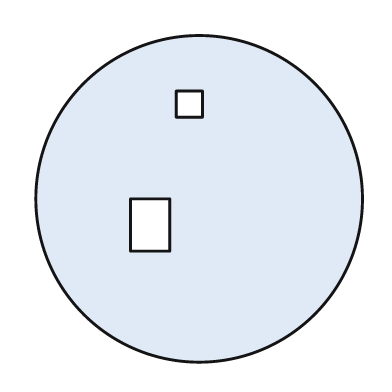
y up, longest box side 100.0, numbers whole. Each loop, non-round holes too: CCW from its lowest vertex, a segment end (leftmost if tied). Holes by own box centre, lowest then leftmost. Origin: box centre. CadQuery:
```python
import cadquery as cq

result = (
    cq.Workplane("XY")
    .moveTo(0.0, 0.0)
    .circle(50.0)
    .moveTo(-21.0, -16.0)
    .lineTo(-9.0, -16.0)
    .lineTo(-9.0, 0.0)
    .lineTo(-21.0, 0.0)
    .close()
    .moveTo(-7.0, 25.0)
    .lineTo(1.0, 25.0)
    .lineTo(1.0, 33.0)
    .lineTo(-7.0, 33.0)
    .close()
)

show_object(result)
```